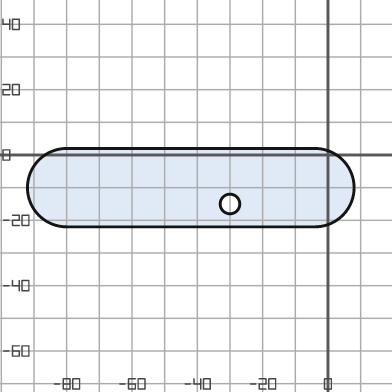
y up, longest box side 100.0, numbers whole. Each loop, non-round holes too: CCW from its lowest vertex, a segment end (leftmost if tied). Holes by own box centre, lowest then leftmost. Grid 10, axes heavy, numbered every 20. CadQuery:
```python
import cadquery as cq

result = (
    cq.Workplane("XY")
    .moveTo(-80.0, -22.0)
    .lineTo(-4.0, -22.0)
    .threePointArc((8.0, -10.0), (-4.0, 2.0))
    .lineTo(-80.0, 2.0)
    .threePointArc((-92.0, -10.0), (-80.0, -22.0))
    .close()
    .moveTo(-30.0, -15.0)
    .circle(3.0)
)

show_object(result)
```